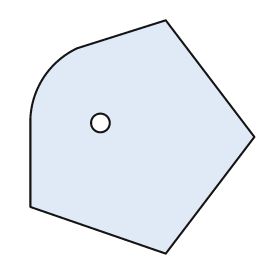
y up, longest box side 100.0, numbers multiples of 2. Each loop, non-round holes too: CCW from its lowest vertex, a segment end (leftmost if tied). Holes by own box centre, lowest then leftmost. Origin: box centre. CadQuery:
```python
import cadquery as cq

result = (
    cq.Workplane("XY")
    .moveTo(10.0, -50.0)
    .lineTo(48.0, 0.0)
    .lineTo(10.0, 50.0)
    .lineTo(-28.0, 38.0)
    .threePointArc((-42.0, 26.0), (-48.0, 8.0))
    .lineTo(-48.0, -30.0)
    .close()
    .moveTo(-18.0, 6.0)
    .circle(4.0)
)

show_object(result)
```